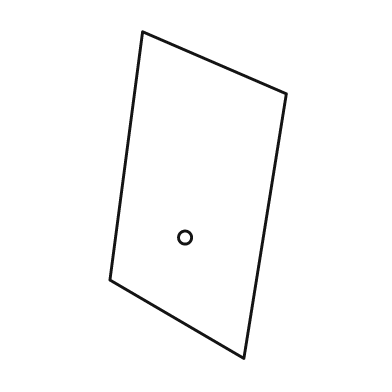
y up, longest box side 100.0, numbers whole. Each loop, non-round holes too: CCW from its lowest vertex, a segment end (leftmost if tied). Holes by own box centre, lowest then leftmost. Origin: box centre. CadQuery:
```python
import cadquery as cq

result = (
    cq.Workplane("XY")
    .moveTo(14.0, -50.0)
    .lineTo(27.0, 31.0)
    .lineTo(-17.0, 50.0)
    .lineTo(-27.0, -26.0)
    .close()
    .moveTo(-4.0, -13.0)
    .circle(2.0)
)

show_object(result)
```